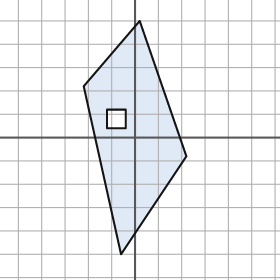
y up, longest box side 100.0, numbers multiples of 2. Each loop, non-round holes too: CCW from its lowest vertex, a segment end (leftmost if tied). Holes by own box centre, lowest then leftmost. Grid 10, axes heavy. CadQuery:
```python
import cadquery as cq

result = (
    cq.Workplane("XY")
    .moveTo(-6.0, -50.0)
    .lineTo(22.0, -8.0)
    .lineTo(2.0, 50.0)
    .lineTo(-22.0, 22.0)
    .close()
    .moveTo(-12.0, 4.0)
    .lineTo(-4.0, 4.0)
    .lineTo(-4.0, 12.0)
    .lineTo(-12.0, 12.0)
    .close()
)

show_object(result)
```